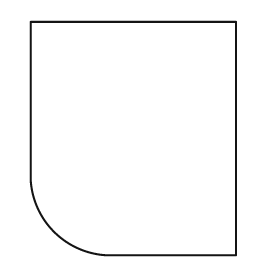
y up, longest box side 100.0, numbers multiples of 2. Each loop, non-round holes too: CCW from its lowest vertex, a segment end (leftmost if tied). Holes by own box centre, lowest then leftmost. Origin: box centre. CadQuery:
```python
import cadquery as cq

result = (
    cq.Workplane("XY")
    .moveTo(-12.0, -50.0)
    .lineTo(44.0, -50.0)
    .lineTo(44.0, 50.0)
    .lineTo(-44.0, 50.0)
    .lineTo(-44.0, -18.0)
    .threePointArc((-34.0, -40.0), (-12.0, -50.0))
    .close()
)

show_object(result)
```